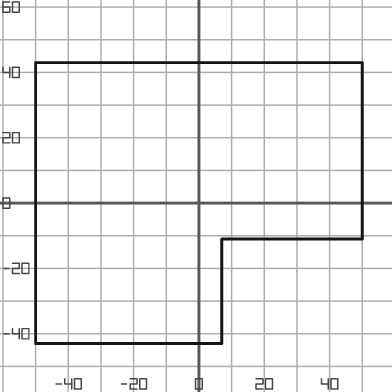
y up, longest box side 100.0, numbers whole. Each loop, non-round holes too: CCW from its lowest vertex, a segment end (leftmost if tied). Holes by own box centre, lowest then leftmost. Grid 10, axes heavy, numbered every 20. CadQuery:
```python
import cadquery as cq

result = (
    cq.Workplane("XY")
    .moveTo(-50.0, -43.0)
    .lineTo(7.0, -43.0)
    .lineTo(7.0, -11.0)
    .lineTo(50.0, -11.0)
    .lineTo(50.0, 43.0)
    .lineTo(-50.0, 43.0)
    .close()
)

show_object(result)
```